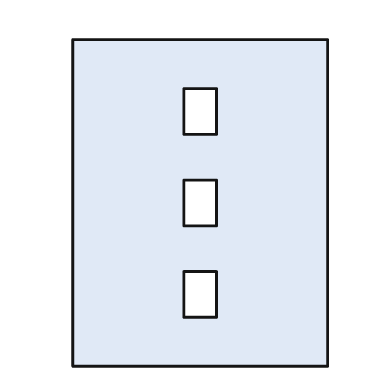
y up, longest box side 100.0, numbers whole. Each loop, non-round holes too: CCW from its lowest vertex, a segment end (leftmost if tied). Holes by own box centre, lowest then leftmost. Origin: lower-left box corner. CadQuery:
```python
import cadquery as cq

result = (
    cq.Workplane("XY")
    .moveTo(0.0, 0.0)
    .lineTo(78.0, 0.0)
    .lineTo(78.0, 100.0)
    .lineTo(0.0, 100.0)
    .close()
    .moveTo(34.0, 15.0)
    .lineTo(44.0, 15.0)
    .lineTo(44.0, 29.0)
    .lineTo(34.0, 29.0)
    .close()
    .moveTo(34.0, 43.0)
    .lineTo(44.0, 43.0)
    .lineTo(44.0, 57.0)
    .lineTo(34.0, 57.0)
    .close()
    .moveTo(34.0, 71.0)
    .lineTo(44.0, 71.0)
    .lineTo(44.0, 85.0)
    .lineTo(34.0, 85.0)
    .close()
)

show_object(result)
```